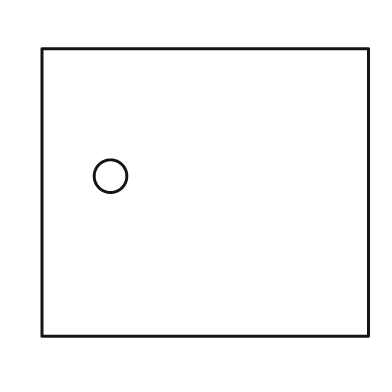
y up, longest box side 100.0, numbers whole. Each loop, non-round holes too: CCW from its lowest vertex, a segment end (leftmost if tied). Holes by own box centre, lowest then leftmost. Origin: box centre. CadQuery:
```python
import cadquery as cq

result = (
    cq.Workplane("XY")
    .moveTo(-50.0, -44.0)
    .lineTo(50.0, -44.0)
    .lineTo(50.0, 44.0)
    .lineTo(-50.0, 44.0)
    .close()
    .moveTo(-29.0, 5.0)
    .circle(5.0)
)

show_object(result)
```